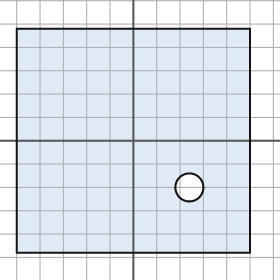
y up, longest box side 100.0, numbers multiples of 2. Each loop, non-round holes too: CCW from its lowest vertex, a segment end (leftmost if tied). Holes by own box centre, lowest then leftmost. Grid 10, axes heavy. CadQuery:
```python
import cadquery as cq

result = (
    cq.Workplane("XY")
    .moveTo(-50.0, -48.0)
    .lineTo(50.0, -48.0)
    .lineTo(50.0, 48.0)
    .lineTo(-50.0, 48.0)
    .close()
    .moveTo(24.0, -20.0)
    .circle(6.0)
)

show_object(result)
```